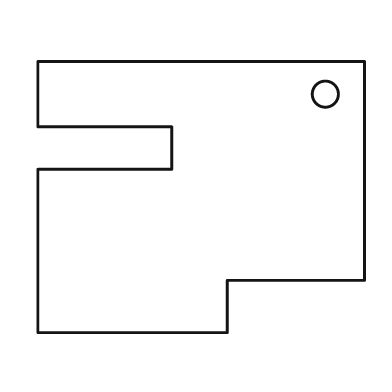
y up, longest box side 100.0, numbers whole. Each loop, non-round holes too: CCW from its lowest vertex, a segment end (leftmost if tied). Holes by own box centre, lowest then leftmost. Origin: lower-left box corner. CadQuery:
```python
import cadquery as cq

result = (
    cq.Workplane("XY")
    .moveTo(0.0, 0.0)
    .lineTo(58.0, 0.0)
    .lineTo(58.0, 16.0)
    .lineTo(100.0, 16.0)
    .lineTo(100.0, 83.0)
    .lineTo(0.0, 83.0)
    .lineTo(0.0, 63.0)
    .lineTo(41.0, 63.0)
    .lineTo(41.0, 50.0)
    .lineTo(0.0, 50.0)
    .close()
    .moveTo(88.0, 73.0)
    .circle(4.0)
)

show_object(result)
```